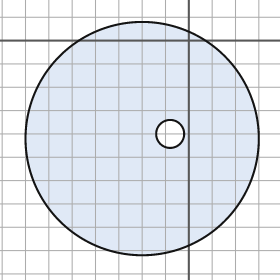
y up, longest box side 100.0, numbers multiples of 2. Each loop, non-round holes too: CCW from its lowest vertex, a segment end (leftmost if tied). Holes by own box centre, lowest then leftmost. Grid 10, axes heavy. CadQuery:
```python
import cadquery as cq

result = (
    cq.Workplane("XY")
    .moveTo(-20.0, -42.0)
    .circle(50.0)
    .moveTo(-8.0, -40.0)
    .circle(6.0)
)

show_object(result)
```